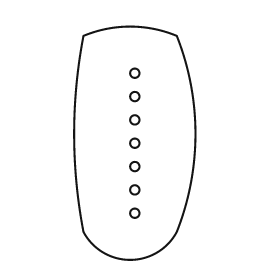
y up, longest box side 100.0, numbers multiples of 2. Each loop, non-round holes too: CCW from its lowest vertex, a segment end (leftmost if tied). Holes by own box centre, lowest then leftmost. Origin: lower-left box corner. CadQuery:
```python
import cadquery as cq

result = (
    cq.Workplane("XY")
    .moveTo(4.0, 12.0)
    .threePointArc((24.0, 0.0), (44.0, 12.0))
    .threePointArc((52.0, 54.0), (44.0, 96.0))
    .threePointArc((24.0, 100.0), (4.0, 96.0))
    .threePointArc((0.0, 54.0), (4.0, 12.0))
    .close()
    .moveTo(26.0, 20.0)
    .circle(2.0)
    .moveTo(26.0, 30.0)
    .circle(2.0)
    .moveTo(26.0, 40.0)
    .circle(2.0)
    .moveTo(26.0, 50.0)
    .circle(2.0)
    .moveTo(26.0, 60.0)
    .circle(2.0)
    .moveTo(26.0, 70.0)
    .circle(2.0)
    .moveTo(26.0, 80.0)
    .circle(2.0)
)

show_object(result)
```